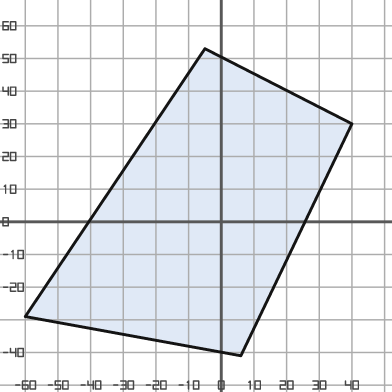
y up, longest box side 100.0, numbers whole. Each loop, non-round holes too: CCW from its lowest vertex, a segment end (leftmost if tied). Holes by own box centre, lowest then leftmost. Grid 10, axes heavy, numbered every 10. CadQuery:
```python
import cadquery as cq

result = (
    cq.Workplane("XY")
    .moveTo(6.0, -41.0)
    .lineTo(40.0, 30.0)
    .lineTo(-5.0, 53.0)
    .lineTo(-60.0, -29.0)
    .close()
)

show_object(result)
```